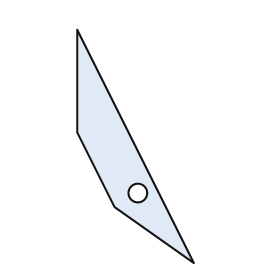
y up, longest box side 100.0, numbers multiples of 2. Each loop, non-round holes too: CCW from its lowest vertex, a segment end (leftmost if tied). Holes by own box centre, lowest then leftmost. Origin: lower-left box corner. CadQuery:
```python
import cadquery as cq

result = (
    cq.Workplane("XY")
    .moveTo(50.0, 0.0)
    .lineTo(0.0, 100.0)
    .lineTo(0.0, 56.0)
    .lineTo(16.0, 24.0)
    .close()
    .moveTo(26.0, 30.0)
    .circle(4.0)
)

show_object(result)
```